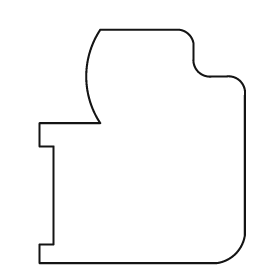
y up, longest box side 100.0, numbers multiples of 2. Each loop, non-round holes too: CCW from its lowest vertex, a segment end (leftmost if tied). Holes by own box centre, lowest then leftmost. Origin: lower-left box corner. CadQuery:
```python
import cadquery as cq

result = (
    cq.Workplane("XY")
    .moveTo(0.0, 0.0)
    .lineTo(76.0, 0.0)
    .threePointArc((84.0, 4.0), (88.0, 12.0))
    .lineTo(88.0, 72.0)
    .threePointArc((86.0, 78.0), (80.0, 80.0))
    .lineTo(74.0, 80.0)
    .threePointArc((68.0, 82.0), (66.0, 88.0))
    .lineTo(66.0, 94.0)
    .threePointArc((64.0, 98.0), (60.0, 100.0))
    .lineTo(26.0, 100.0)
    .threePointArc((20.0, 80.0), (26.0, 60.0))
    .lineTo(0.0, 60.0)
    .lineTo(0.0, 50.0)
    .lineTo(6.0, 50.0)
    .lineTo(6.0, 8.0)
    .lineTo(0.0, 8.0)
    .close()
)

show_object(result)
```